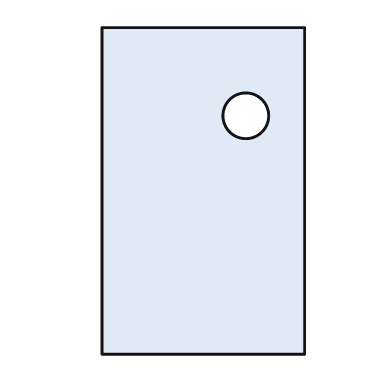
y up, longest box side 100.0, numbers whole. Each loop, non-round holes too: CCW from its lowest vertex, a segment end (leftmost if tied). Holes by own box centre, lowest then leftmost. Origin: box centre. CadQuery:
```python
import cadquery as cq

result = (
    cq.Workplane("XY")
    .moveTo(-31.0, -50.0)
    .lineTo(31.0, -50.0)
    .lineTo(31.0, 50.0)
    .lineTo(-31.0, 50.0)
    .close()
    .moveTo(13.0, 23.0)
    .circle(7.0)
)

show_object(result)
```